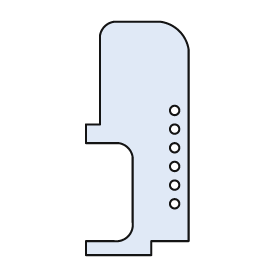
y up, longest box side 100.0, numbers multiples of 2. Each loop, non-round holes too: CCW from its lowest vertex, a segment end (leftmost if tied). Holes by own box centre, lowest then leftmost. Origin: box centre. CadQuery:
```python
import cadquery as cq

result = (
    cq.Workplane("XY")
    .moveTo(-22.0, -50.0)
    .lineTo(6.0, -50.0)
    .lineTo(6.0, -44.0)
    .lineTo(22.0, -44.0)
    .lineTo(22.0, 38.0)
    .threePointArc((18.0, 46.0), (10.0, 50.0))
    .lineTo(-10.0, 50.0)
    .threePointArc((-14.0, 48.0), (-16.0, 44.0))
    .lineTo(-16.0, 6.0)
    .lineTo(-22.0, 6.0)
    .lineTo(-22.0, -2.0)
    .lineTo(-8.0, -2.0)
    .threePointArc((-4.0, -4.0), (-2.0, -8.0))
    .lineTo(-2.0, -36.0)
    .threePointArc((-4.0, -42.0), (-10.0, -44.0))
    .lineTo(-22.0, -44.0)
    .close()
    .moveTo(16.0, -28.0)
    .circle(2.0)
    .moveTo(16.0, -20.0)
    .circle(2.0)
    .moveTo(16.0, -12.0)
    .circle(2.0)
    .moveTo(16.0, -4.0)
    .circle(2.0)
    .moveTo(16.0, 4.0)
    .circle(2.0)
    .moveTo(16.0, 12.0)
    .circle(2.0)
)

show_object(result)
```